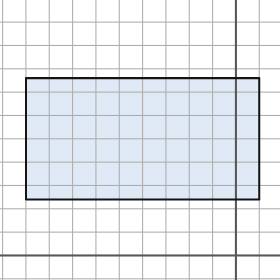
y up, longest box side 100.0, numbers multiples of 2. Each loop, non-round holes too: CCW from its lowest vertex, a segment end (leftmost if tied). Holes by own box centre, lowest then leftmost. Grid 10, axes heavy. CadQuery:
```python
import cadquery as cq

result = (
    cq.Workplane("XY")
    .moveTo(-90.0, 24.0)
    .lineTo(10.0, 24.0)
    .lineTo(10.0, 76.0)
    .lineTo(-90.0, 76.0)
    .close()
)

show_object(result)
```